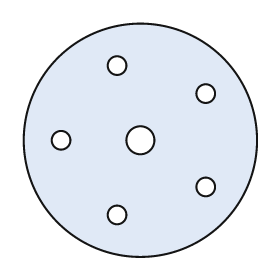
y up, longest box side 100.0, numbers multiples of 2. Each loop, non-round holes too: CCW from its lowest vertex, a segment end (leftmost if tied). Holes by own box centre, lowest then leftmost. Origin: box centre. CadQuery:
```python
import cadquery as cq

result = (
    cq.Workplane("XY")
    .moveTo(0.0, 0.0)
    .circle(50.0)
    .moveTo(-10.0, -32.0)
    .circle(4.0)
    .moveTo(28.0, -20.0)
    .circle(4.0)
    .moveTo(-34.0, 0.0)
    .circle(4.0)
    .moveTo(0.0, 0.0)
    .circle(6.0)
    .moveTo(28.0, 20.0)
    .circle(4.0)
    .moveTo(-10.0, 32.0)
    .circle(4.0)
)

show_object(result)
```